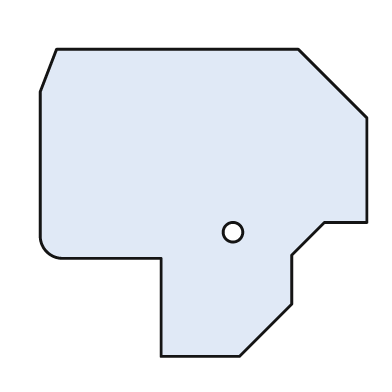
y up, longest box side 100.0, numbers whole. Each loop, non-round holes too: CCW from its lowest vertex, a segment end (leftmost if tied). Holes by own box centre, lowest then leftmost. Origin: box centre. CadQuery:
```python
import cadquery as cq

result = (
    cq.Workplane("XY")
    .moveTo(-13.0, -47.0)
    .lineTo(11.0, -47.0)
    .lineTo(27.0, -31.0)
    .lineTo(27.0, -16.0)
    .lineTo(37.0, -6.0)
    .lineTo(50.0, -6.0)
    .lineTo(50.0, 26.0)
    .lineTo(29.0, 47.0)
    .lineTo(-45.0, 47.0)
    .lineTo(-50.0, 34.0)
    .lineTo(-50.0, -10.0)
    .threePointArc((-48.0, -15.0), (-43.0, -17.0))
    .lineTo(-13.0, -17.0)
    .close()
    .moveTo(9.0, -9.0)
    .circle(3.0)
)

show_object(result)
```